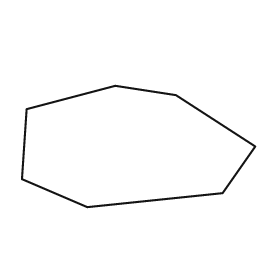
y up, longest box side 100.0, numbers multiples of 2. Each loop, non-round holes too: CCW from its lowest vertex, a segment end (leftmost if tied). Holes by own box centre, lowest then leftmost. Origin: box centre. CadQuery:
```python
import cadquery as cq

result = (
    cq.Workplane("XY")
    .moveTo(-22.0, -26.0)
    .lineTo(36.0, -20.0)
    .lineTo(50.0, 0.0)
    .lineTo(16.0, 22.0)
    .lineTo(-10.0, 26.0)
    .lineTo(-48.0, 16.0)
    .lineTo(-50.0, -14.0)
    .close()
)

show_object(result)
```